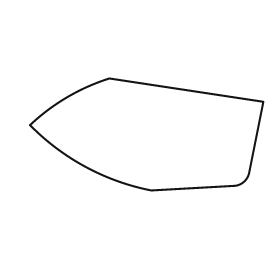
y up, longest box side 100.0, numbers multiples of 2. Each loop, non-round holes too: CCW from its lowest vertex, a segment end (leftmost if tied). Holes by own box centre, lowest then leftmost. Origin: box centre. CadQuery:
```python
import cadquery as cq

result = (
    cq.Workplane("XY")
    .moveTo(2.0, -24.0)
    .lineTo(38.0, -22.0)
    .threePointArc((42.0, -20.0), (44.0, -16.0))
    .lineTo(50.0, 14.0)
    .lineTo(-16.0, 24.0)
    .threePointArc((-34.0, 16.0), (-50.0, 4.0))
    .threePointArc((-26.0, -14.0), (2.0, -24.0))
    .close()
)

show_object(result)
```